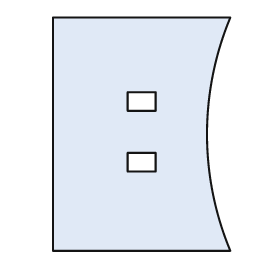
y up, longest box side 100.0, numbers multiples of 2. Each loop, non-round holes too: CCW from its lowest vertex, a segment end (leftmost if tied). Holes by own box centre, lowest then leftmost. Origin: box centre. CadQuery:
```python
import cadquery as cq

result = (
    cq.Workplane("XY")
    .moveTo(-38.0, -50.0)
    .lineTo(38.0, -50.0)
    .threePointArc((28.0, 0.0), (38.0, 50.0))
    .lineTo(-38.0, 50.0)
    .close()
    .moveTo(-6.0, -16.0)
    .lineTo(6.0, -16.0)
    .lineTo(6.0, -8.0)
    .lineTo(-6.0, -8.0)
    .close()
    .moveTo(-6.0, 10.0)
    .lineTo(6.0, 10.0)
    .lineTo(6.0, 18.0)
    .lineTo(-6.0, 18.0)
    .close()
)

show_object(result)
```